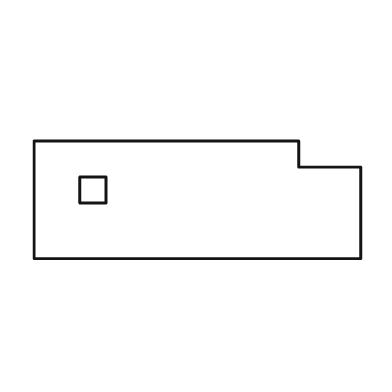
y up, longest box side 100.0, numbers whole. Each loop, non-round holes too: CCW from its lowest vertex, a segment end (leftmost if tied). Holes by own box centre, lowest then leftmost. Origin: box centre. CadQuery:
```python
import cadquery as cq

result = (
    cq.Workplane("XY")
    .moveTo(-50.0, -18.0)
    .lineTo(50.0, -18.0)
    .lineTo(50.0, 10.0)
    .lineTo(31.0, 10.0)
    .lineTo(31.0, 18.0)
    .lineTo(-50.0, 18.0)
    .close()
    .moveTo(-36.0, -1.0)
    .lineTo(-28.0, -1.0)
    .lineTo(-28.0, 7.0)
    .lineTo(-36.0, 7.0)
    .close()
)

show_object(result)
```